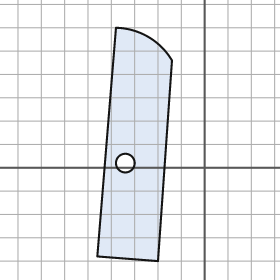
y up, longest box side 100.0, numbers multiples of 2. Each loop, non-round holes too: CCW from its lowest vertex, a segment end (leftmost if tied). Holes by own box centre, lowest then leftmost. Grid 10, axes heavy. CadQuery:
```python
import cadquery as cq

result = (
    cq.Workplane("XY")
    .moveTo(-20.0, -40.0)
    .lineTo(-14.0, 46.0)
    .threePointArc((-24.0, 56.0), (-38.0, 60.0))
    .lineTo(-46.0, -38.0)
    .close()
    .moveTo(-34.0, 2.0)
    .circle(4.0)
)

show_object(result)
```